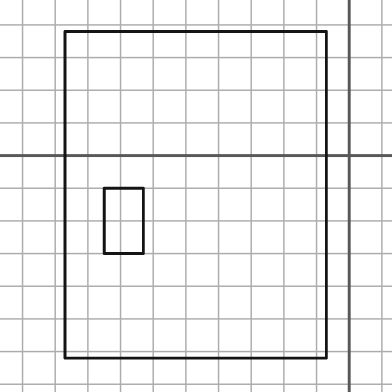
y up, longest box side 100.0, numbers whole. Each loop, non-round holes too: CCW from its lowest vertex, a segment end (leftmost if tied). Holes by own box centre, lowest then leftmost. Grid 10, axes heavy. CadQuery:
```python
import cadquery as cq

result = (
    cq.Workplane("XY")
    .moveTo(-87.0, -62.0)
    .lineTo(-7.0, -62.0)
    .lineTo(-7.0, 38.0)
    .lineTo(-87.0, 38.0)
    .close()
    .moveTo(-75.0, -30.0)
    .lineTo(-63.0, -30.0)
    .lineTo(-63.0, -10.0)
    .lineTo(-75.0, -10.0)
    .close()
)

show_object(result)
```